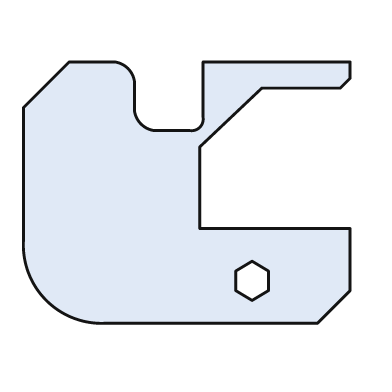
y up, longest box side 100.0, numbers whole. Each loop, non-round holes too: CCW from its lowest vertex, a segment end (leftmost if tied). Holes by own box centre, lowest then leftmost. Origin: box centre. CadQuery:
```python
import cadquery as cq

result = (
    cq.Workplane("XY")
    .moveTo(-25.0, -40.0)
    .lineTo(40.0, -40.0)
    .lineTo(50.0, -30.0)
    .lineTo(50.0, -11.0)
    .lineTo(4.0, -11.0)
    .lineTo(4.0, 14.0)
    .lineTo(23.0, 32.0)
    .lineTo(47.0, 32.0)
    .lineTo(50.0, 35.0)
    .lineTo(50.0, 40.0)
    .lineTo(5.0, 40.0)
    .lineTo(5.0, 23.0)
    .threePointArc((4.0, 20.0), (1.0, 19.0))
    .lineTo(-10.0, 19.0)
    .threePointArc((-14.0, 21.0), (-16.0, 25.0))
    .lineTo(-16.0, 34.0)
    .threePointArc((-18.0, 38.0), (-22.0, 40.0))
    .lineTo(-36.0, 40.0)
    .lineTo(-50.0, 26.0)
    .lineTo(-50.0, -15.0)
    .threePointArc((-43.0, -33.0), (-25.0, -40.0))
    .close()
    .moveTo(20.0, -33.0)
    .lineTo(25.0, -30.0)
    .lineTo(25.0, -24.0)
    .lineTo(20.0, -21.0)
    .lineTo(15.0, -24.0)
    .lineTo(15.0, -30.0)
    .close()
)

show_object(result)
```